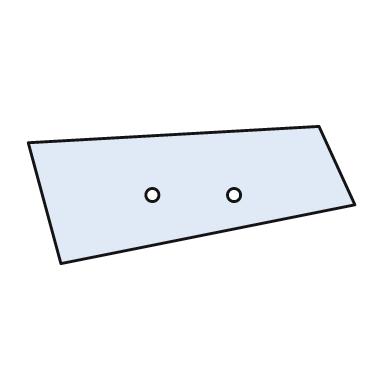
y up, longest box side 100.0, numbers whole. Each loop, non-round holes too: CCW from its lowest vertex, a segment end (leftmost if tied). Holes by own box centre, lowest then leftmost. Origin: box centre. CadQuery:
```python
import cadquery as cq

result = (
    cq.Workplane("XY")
    .moveTo(-40.0, -21.0)
    .lineTo(50.0, -3.0)
    .lineTo(39.0, 21.0)
    .lineTo(-50.0, 16.0)
    .close()
    .moveTo(-12.0, 0.0)
    .circle(2.0)
    .moveTo(13.0, 0.0)
    .circle(2.0)
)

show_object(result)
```